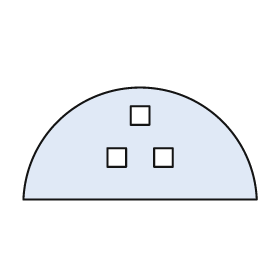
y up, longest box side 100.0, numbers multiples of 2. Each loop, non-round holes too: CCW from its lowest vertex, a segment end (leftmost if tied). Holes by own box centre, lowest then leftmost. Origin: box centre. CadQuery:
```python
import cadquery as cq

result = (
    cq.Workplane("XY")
    .moveTo(-50.0, -24.0)
    .lineTo(50.0, -24.0)
    .threePointArc((0.0, 24.0), (-50.0, -24.0))
    .close()
    .moveTo(-14.0, -10.0)
    .lineTo(-6.0, -10.0)
    .lineTo(-6.0, -2.0)
    .lineTo(-14.0, -2.0)
    .close()
    .moveTo(6.0, -10.0)
    .lineTo(14.0, -10.0)
    .lineTo(14.0, -2.0)
    .lineTo(6.0, -2.0)
    .close()
    .moveTo(-4.0, 8.0)
    .lineTo(4.0, 8.0)
    .lineTo(4.0, 16.0)
    .lineTo(-4.0, 16.0)
    .close()
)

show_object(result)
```